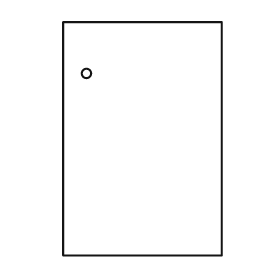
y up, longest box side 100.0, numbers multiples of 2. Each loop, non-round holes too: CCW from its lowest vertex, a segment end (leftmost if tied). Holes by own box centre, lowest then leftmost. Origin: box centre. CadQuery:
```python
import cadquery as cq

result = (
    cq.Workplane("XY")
    .moveTo(-34.0, -50.0)
    .lineTo(34.0, -50.0)
    .lineTo(34.0, 50.0)
    .lineTo(-34.0, 50.0)
    .close()
    .moveTo(-24.0, 28.0)
    .circle(2.0)
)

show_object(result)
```